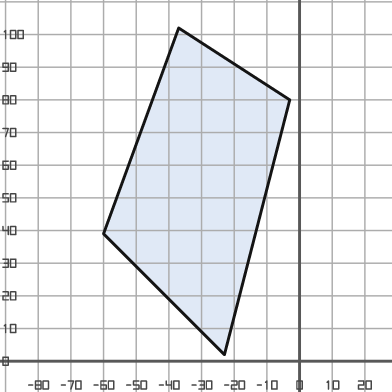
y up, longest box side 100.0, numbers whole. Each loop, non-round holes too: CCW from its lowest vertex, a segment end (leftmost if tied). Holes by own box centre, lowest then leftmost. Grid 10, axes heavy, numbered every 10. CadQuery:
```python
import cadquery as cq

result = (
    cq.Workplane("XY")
    .moveTo(-23.0, 2.0)
    .lineTo(-3.0, 80.0)
    .lineTo(-37.0, 102.0)
    .lineTo(-60.0, 39.0)
    .close()
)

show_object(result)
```